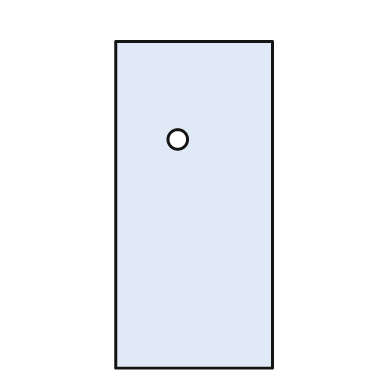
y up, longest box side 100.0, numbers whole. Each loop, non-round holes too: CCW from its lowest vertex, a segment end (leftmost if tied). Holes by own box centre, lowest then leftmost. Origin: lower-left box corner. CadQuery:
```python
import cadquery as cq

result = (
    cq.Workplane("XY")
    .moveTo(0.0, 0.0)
    .lineTo(48.0, 0.0)
    .lineTo(48.0, 100.0)
    .lineTo(0.0, 100.0)
    .close()
    .moveTo(19.0, 70.0)
    .circle(3.0)
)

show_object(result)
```